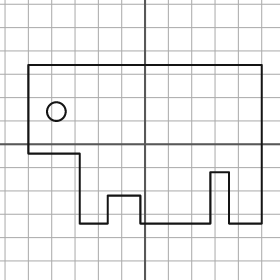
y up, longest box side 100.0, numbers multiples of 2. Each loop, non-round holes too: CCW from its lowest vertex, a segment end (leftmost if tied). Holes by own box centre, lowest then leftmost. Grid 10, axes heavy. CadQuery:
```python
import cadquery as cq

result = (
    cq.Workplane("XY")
    .moveTo(-28.0, -34.0)
    .lineTo(-16.0, -34.0)
    .lineTo(-16.0, -22.0)
    .lineTo(-2.0, -22.0)
    .lineTo(-2.0, -34.0)
    .lineTo(28.0, -34.0)
    .lineTo(28.0, -12.0)
    .lineTo(36.0, -12.0)
    .lineTo(36.0, -34.0)
    .lineTo(50.0, -34.0)
    .lineTo(50.0, 34.0)
    .lineTo(-50.0, 34.0)
    .lineTo(-50.0, -4.0)
    .lineTo(-28.0, -4.0)
    .close()
    .moveTo(-38.0, 14.0)
    .circle(4.0)
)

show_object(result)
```